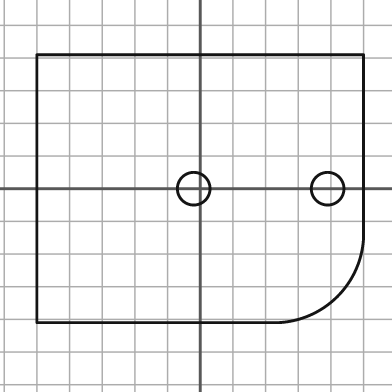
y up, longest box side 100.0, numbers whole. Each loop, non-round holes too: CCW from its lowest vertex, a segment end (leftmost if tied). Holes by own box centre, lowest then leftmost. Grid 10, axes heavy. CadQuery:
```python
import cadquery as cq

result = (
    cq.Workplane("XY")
    .moveTo(-50.0, -41.0)
    .lineTo(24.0, -41.0)
    .threePointArc((42.0, -33.0), (50.0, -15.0))
    .lineTo(50.0, 41.0)
    .lineTo(-50.0, 41.0)
    .close()
    .moveTo(-2.0, 0.0)
    .circle(5.0)
    .moveTo(39.0, 0.0)
    .circle(5.0)
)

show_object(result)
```